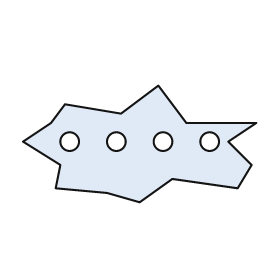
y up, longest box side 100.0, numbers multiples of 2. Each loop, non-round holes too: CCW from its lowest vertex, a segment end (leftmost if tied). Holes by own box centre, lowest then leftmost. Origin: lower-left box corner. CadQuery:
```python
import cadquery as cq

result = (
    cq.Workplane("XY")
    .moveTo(50.0, 0.0)
    .lineTo(64.0, 10.0)
    .lineTo(92.0, 6.0)
    .lineTo(98.0, 16.0)
    .lineTo(88.0, 26.0)
    .lineTo(100.0, 34.0)
    .lineTo(70.0, 34.0)
    .lineTo(58.0, 50.0)
    .lineTo(42.0, 38.0)
    .lineTo(18.0, 42.0)
    .lineTo(12.0, 34.0)
    .lineTo(0.0, 26.0)
    .lineTo(16.0, 16.0)
    .lineTo(14.0, 6.0)
    .lineTo(36.0, 4.0)
    .close()
    .moveTo(20.0, 26.0)
    .circle(4.0)
    .moveTo(40.0, 26.0)
    .circle(4.0)
    .moveTo(60.0, 26.0)
    .circle(4.0)
    .moveTo(80.0, 26.0)
    .circle(4.0)
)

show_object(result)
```